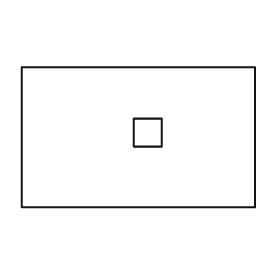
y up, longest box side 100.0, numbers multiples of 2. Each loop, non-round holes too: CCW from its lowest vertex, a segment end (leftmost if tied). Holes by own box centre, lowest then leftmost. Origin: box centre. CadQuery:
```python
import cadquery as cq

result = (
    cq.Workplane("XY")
    .moveTo(-50.0, -30.0)
    .lineTo(50.0, -30.0)
    .lineTo(50.0, 30.0)
    .lineTo(-50.0, 30.0)
    .close()
    .moveTo(-2.0, -4.0)
    .lineTo(10.0, -4.0)
    .lineTo(10.0, 8.0)
    .lineTo(-2.0, 8.0)
    .close()
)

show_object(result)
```